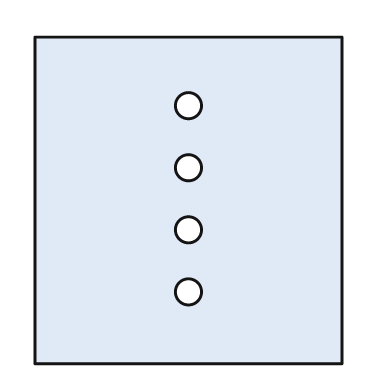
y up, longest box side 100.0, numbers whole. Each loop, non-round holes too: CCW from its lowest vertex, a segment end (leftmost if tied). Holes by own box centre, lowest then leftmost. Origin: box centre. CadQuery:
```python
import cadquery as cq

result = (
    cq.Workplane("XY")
    .moveTo(-47.0, -50.0)
    .lineTo(47.0, -50.0)
    .lineTo(47.0, 50.0)
    .lineTo(-47.0, 50.0)
    .close()
    .moveTo(0.0, -28.0)
    .circle(4.0)
    .moveTo(0.0, -9.0)
    .circle(4.0)
    .moveTo(0.0, 10.0)
    .circle(4.0)
    .moveTo(0.0, 29.0)
    .circle(4.0)
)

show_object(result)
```